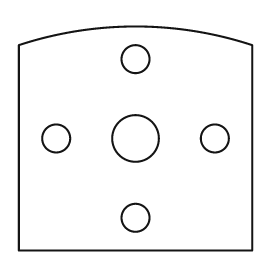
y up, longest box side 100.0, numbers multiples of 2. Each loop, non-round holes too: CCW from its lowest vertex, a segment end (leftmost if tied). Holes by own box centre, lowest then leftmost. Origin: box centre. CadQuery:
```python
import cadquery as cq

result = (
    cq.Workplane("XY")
    .moveTo(-50.0, -48.0)
    .lineTo(50.0, -48.0)
    .lineTo(50.0, 40.0)
    .threePointArc((0.0, 48.0), (-50.0, 40.0))
    .close()
    .moveTo(0.0, -34.0)
    .circle(6.0)
    .moveTo(-34.0, 0.0)
    .circle(6.0)
    .moveTo(0.0, 0.0)
    .circle(10.0)
    .moveTo(34.0, 0.0)
    .circle(6.0)
    .moveTo(0.0, 34.0)
    .circle(6.0)
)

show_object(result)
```